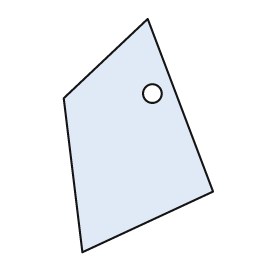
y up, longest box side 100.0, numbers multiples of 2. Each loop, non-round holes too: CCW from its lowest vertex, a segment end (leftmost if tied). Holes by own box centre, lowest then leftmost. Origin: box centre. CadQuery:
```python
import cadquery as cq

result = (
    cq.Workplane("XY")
    .moveTo(-24.0, -50.0)
    .lineTo(32.0, -24.0)
    .lineTo(4.0, 50.0)
    .lineTo(-32.0, 16.0)
    .close()
    .moveTo(6.0, 18.0)
    .circle(4.0)
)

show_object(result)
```